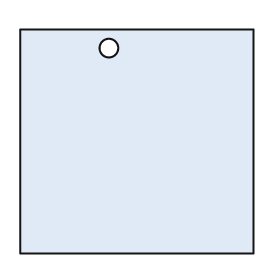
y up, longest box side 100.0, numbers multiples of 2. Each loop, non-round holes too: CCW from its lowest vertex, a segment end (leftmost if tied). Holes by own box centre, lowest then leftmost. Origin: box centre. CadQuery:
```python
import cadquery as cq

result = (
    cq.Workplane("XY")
    .moveTo(-50.0, -48.0)
    .lineTo(50.0, -48.0)
    .lineTo(50.0, 48.0)
    .lineTo(-50.0, 48.0)
    .close()
    .moveTo(-12.0, 40.0)
    .circle(4.0)
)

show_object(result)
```